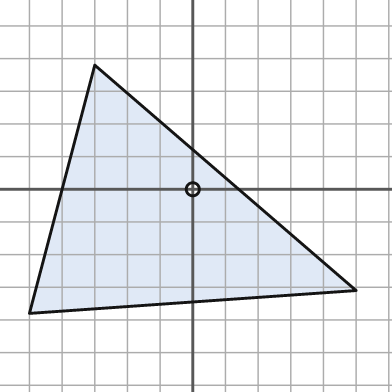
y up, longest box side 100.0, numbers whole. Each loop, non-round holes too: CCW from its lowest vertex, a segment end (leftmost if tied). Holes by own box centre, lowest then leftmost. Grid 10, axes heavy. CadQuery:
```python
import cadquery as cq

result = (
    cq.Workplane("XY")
    .moveTo(-50.0, -38.0)
    .lineTo(50.0, -31.0)
    .lineTo(-30.0, 38.0)
    .close()
    .moveTo(0.0, 0.0)
    .circle(2.0)
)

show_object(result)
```